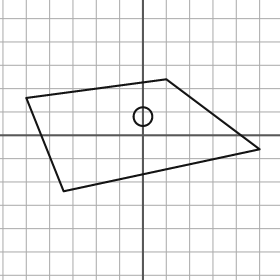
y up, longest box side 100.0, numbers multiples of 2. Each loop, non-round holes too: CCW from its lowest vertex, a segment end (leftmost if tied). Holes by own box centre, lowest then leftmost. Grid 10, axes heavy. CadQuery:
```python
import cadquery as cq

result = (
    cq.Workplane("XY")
    .moveTo(-34.0, -24.0)
    .lineTo(50.0, -6.0)
    .lineTo(10.0, 24.0)
    .lineTo(-50.0, 16.0)
    .close()
    .moveTo(0.0, 8.0)
    .circle(4.0)
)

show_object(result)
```